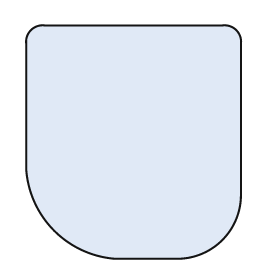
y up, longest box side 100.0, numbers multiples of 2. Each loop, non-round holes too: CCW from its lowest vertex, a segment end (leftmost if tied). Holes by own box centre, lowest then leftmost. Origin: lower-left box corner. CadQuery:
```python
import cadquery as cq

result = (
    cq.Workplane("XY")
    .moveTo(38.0, 0.0)
    .lineTo(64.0, 0.0)
    .threePointArc((84.0, 8.0), (92.0, 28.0))
    .lineTo(92.0, 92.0)
    .threePointArc((90.0, 98.0), (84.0, 100.0))
    .lineTo(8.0, 100.0)
    .threePointArc((2.0, 98.0), (0.0, 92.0))
    .lineTo(0.0, 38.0)
    .threePointArc((12.0, 12.0), (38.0, 0.0))
    .close()
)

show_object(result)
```